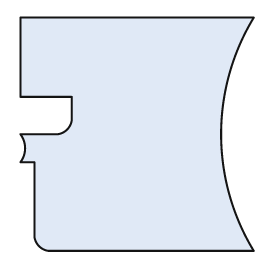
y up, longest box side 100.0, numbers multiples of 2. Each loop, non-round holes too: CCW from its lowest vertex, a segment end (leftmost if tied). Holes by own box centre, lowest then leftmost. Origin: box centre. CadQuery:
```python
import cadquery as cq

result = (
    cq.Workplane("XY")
    .moveTo(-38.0, -50.0)
    .lineTo(50.0, -50.0)
    .threePointArc((36.0, 0.0), (50.0, 50.0))
    .lineTo(-50.0, 50.0)
    .lineTo(-50.0, 16.0)
    .lineTo(-28.0, 16.0)
    .lineTo(-28.0, 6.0)
    .threePointArc((-30.0, 2.0), (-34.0, 0.0))
    .lineTo(-50.0, 0.0)
    .threePointArc((-48.0, -6.0), (-50.0, -12.0))
    .lineTo(-44.0, -12.0)
    .lineTo(-44.0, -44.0)
    .threePointArc((-42.0, -48.0), (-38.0, -50.0))
    .close()
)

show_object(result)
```